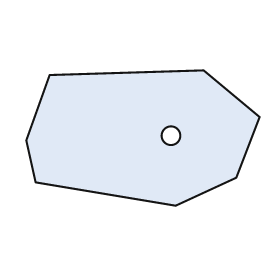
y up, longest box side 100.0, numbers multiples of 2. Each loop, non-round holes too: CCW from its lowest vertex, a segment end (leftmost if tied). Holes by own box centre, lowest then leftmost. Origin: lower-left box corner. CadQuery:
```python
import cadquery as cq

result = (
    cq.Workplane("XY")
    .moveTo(64.0, 0.0)
    .lineTo(90.0, 12.0)
    .lineTo(100.0, 38.0)
    .lineTo(76.0, 58.0)
    .lineTo(10.0, 56.0)
    .lineTo(0.0, 28.0)
    .lineTo(4.0, 10.0)
    .close()
    .moveTo(62.0, 30.0)
    .circle(4.0)
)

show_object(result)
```